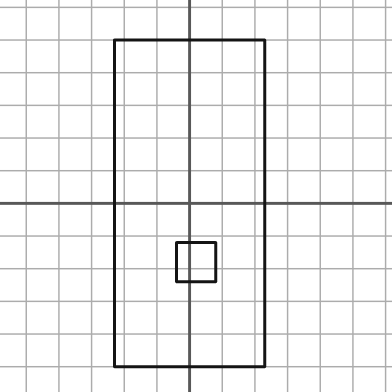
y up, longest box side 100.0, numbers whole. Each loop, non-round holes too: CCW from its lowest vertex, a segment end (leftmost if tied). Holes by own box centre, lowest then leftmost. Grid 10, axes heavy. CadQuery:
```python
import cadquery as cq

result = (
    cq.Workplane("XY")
    .moveTo(-23.0, -50.0)
    .lineTo(23.0, -50.0)
    .lineTo(23.0, 50.0)
    .lineTo(-23.0, 50.0)
    .close()
    .moveTo(-4.0, -24.0)
    .lineTo(8.0, -24.0)
    .lineTo(8.0, -12.0)
    .lineTo(-4.0, -12.0)
    .close()
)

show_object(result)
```